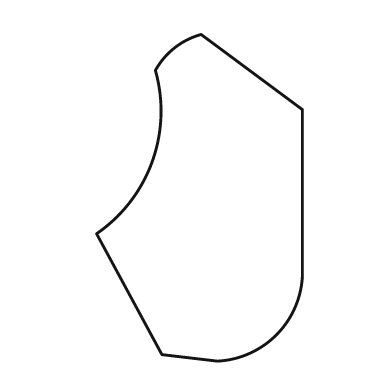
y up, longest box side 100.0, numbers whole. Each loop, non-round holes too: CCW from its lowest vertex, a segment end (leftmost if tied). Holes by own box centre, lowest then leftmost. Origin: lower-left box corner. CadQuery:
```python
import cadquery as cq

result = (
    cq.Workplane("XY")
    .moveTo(37.0, 0.0)
    .threePointArc((55.0, 8.0), (63.0, 26.0))
    .lineTo(63.0, 77.0)
    .lineTo(32.0, 100.0)
    .threePointArc((24.0, 96.0), (18.0, 89.0))
    .threePointArc((17.0, 61.0), (0.0, 39.0))
    .lineTo(20.0, 2.0)
    .close()
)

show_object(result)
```